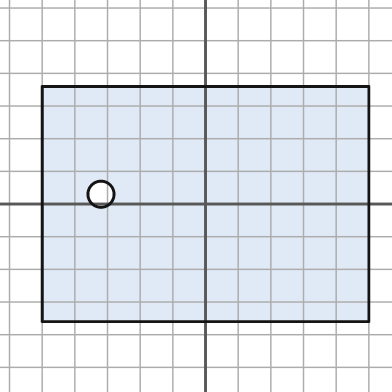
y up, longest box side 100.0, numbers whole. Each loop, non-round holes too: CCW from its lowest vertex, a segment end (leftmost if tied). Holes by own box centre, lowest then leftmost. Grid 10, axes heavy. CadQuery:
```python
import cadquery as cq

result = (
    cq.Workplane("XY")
    .moveTo(-50.0, -36.0)
    .lineTo(50.0, -36.0)
    .lineTo(50.0, 36.0)
    .lineTo(-50.0, 36.0)
    .close()
    .moveTo(-32.0, 3.0)
    .circle(4.0)
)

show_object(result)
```